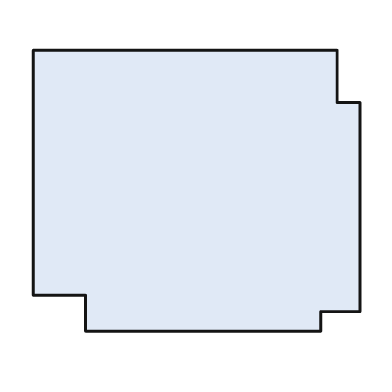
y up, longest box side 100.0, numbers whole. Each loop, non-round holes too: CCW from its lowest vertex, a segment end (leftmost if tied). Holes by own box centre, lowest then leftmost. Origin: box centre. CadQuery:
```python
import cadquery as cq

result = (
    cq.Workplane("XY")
    .moveTo(-34.0, -43.0)
    .lineTo(38.0, -43.0)
    .lineTo(38.0, -37.0)
    .lineTo(50.0, -37.0)
    .lineTo(50.0, 27.0)
    .lineTo(43.0, 27.0)
    .lineTo(43.0, 43.0)
    .lineTo(-50.0, 43.0)
    .lineTo(-50.0, -32.0)
    .lineTo(-34.0, -32.0)
    .close()
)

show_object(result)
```